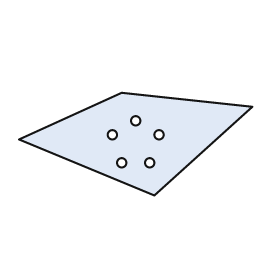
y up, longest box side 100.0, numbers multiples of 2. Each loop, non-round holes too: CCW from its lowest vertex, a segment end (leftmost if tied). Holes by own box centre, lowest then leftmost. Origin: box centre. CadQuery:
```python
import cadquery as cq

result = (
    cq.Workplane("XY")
    .moveTo(8.0, -22.0)
    .lineTo(50.0, 16.0)
    .lineTo(-6.0, 22.0)
    .lineTo(-50.0, 2.0)
    .close()
    .moveTo(-6.0, -8.0)
    .circle(2.0)
    .moveTo(6.0, -8.0)
    .circle(2.0)
    .moveTo(-10.0, 4.0)
    .circle(2.0)
    .moveTo(10.0, 4.0)
    .circle(2.0)
    .moveTo(0.0, 10.0)
    .circle(2.0)
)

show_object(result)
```